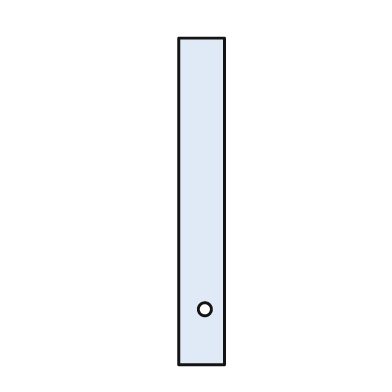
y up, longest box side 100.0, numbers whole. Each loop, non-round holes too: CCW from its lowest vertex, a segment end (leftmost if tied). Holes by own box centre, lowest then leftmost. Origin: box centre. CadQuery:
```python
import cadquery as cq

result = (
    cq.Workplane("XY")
    .moveTo(-7.0, -50.0)
    .lineTo(7.0, -50.0)
    .lineTo(7.0, 50.0)
    .lineTo(-7.0, 50.0)
    .close()
    .moveTo(1.0, -33.0)
    .circle(2.0)
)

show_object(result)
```